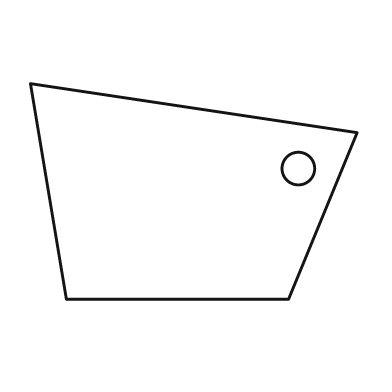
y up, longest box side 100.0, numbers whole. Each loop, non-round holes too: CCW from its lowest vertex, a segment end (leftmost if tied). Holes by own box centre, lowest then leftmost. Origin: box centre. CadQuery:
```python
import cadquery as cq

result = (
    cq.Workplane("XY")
    .moveTo(-39.0, -33.0)
    .lineTo(29.0, -33.0)
    .lineTo(50.0, 18.0)
    .lineTo(-50.0, 33.0)
    .close()
    .moveTo(32.0, 7.0)
    .circle(5.0)
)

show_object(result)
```